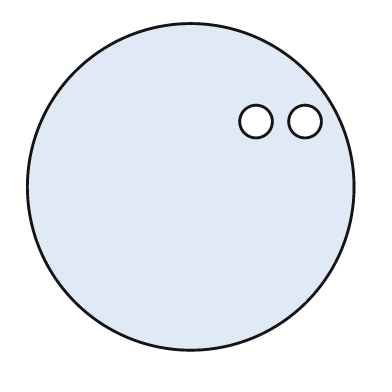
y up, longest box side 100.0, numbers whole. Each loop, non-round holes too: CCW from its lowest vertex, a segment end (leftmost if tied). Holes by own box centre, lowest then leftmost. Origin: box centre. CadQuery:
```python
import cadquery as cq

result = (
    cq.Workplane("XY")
    .moveTo(0.0, 0.0)
    .circle(50.0)
    .moveTo(20.0, 20.0)
    .circle(5.0)
    .moveTo(35.0, 20.0)
    .circle(5.0)
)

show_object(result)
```